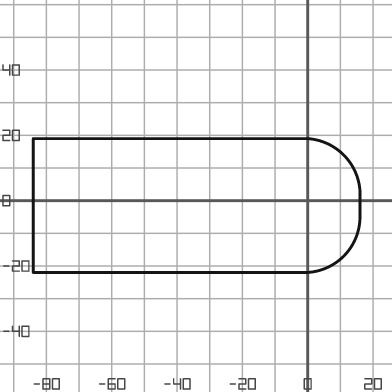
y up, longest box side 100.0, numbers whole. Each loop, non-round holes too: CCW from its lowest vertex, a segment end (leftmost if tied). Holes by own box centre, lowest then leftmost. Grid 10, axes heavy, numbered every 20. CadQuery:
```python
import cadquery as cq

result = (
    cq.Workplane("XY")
    .moveTo(-84.0, -22.0)
    .lineTo(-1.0, -22.0)
    .threePointArc((11.0, -17.0), (16.0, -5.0))
    .lineTo(16.0, 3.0)
    .threePointArc((11.0, 14.0), (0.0, 19.0))
    .lineTo(-84.0, 19.0)
    .close()
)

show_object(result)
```